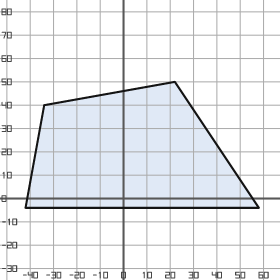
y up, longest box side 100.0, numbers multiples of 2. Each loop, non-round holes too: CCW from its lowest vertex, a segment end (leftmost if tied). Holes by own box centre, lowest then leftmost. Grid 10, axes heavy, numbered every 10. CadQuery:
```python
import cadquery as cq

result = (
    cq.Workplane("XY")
    .moveTo(-42.0, -4.0)
    .lineTo(58.0, -4.0)
    .lineTo(22.0, 50.0)
    .lineTo(-34.0, 40.0)
    .close()
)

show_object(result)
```